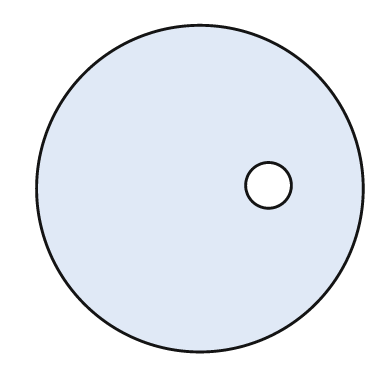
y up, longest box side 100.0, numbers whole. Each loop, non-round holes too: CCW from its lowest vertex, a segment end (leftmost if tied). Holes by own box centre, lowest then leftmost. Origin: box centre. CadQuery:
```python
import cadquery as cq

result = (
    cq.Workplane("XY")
    .moveTo(0.0, 0.0)
    .circle(50.0)
    .moveTo(21.0, 1.0)
    .circle(7.0)
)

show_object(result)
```